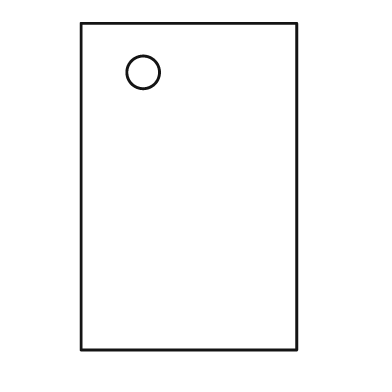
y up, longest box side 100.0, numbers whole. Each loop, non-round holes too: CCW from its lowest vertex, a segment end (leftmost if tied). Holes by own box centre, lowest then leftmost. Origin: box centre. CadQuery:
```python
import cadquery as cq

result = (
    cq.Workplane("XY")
    .moveTo(-33.0, -50.0)
    .lineTo(33.0, -50.0)
    .lineTo(33.0, 50.0)
    .lineTo(-33.0, 50.0)
    .close()
    .moveTo(-14.0, 35.0)
    .circle(5.0)
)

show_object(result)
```